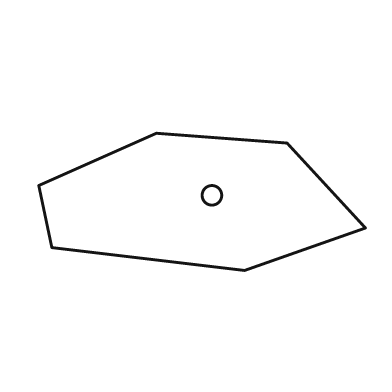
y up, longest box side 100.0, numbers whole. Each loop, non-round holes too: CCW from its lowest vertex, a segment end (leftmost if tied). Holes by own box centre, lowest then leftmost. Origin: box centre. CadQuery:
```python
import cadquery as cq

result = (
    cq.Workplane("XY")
    .moveTo(13.0, -21.0)
    .lineTo(50.0, -8.0)
    .lineTo(26.0, 18.0)
    .lineTo(-14.0, 21.0)
    .lineTo(-50.0, 5.0)
    .lineTo(-46.0, -14.0)
    .close()
    .moveTo(3.0, 2.0)
    .circle(3.0)
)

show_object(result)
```